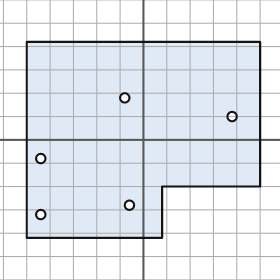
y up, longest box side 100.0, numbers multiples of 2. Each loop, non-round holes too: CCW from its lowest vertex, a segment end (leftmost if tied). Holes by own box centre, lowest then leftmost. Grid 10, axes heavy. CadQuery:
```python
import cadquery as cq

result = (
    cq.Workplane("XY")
    .moveTo(-50.0, -42.0)
    .lineTo(8.0, -42.0)
    .lineTo(8.0, -20.0)
    .lineTo(50.0, -20.0)
    .lineTo(50.0, 42.0)
    .lineTo(-50.0, 42.0)
    .close()
    .moveTo(-44.0, -32.0)
    .circle(2.0)
    .moveTo(-6.0, -28.0)
    .circle(2.0)
    .moveTo(-44.0, -8.0)
    .circle(2.0)
    .moveTo(38.0, 10.0)
    .circle(2.0)
    .moveTo(-8.0, 18.0)
    .circle(2.0)
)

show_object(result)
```